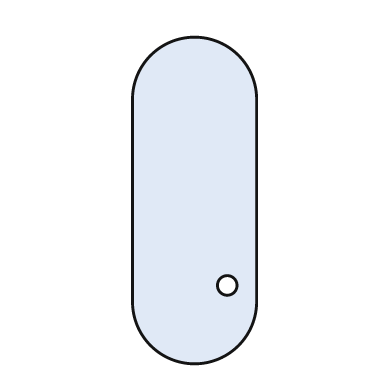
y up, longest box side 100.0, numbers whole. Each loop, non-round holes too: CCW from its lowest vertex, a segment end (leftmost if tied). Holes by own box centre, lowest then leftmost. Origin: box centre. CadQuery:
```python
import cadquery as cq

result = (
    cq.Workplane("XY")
    .moveTo(-19.0, -31.0)
    .threePointArc((0.0, -50.0), (19.0, -31.0))
    .lineTo(19.0, 31.0)
    .threePointArc((0.0, 50.0), (-19.0, 31.0))
    .close()
    .moveTo(10.0, -26.0)
    .circle(3.0)
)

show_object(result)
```